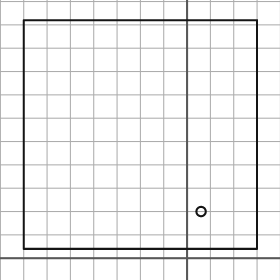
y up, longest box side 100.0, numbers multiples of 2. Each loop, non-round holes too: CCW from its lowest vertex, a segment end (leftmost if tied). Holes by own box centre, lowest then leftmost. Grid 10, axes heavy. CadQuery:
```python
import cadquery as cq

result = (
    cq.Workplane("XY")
    .moveTo(-70.0, 4.0)
    .lineTo(30.0, 4.0)
    .lineTo(30.0, 102.0)
    .lineTo(-70.0, 102.0)
    .close()
    .moveTo(6.0, 20.0)
    .circle(2.0)
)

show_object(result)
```